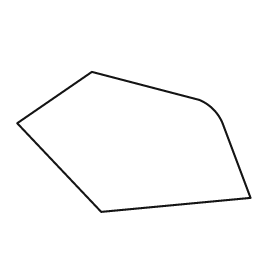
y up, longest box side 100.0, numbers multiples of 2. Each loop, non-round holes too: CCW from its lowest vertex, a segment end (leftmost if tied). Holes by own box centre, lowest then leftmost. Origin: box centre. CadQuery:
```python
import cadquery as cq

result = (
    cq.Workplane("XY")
    .moveTo(-14.0, -30.0)
    .lineTo(50.0, -24.0)
    .lineTo(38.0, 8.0)
    .threePointArc((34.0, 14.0), (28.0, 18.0))
    .lineTo(-18.0, 30.0)
    .lineTo(-50.0, 8.0)
    .close()
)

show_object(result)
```